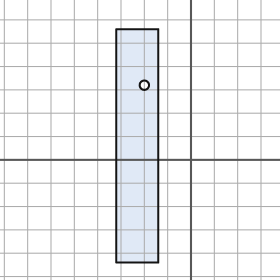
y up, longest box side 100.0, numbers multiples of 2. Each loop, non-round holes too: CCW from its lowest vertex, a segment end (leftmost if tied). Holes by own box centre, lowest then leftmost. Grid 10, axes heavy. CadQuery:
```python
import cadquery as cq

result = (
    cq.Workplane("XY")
    .moveTo(-32.0, -44.0)
    .lineTo(-14.0, -44.0)
    .lineTo(-14.0, 56.0)
    .lineTo(-32.0, 56.0)
    .close()
    .moveTo(-20.0, 32.0)
    .circle(2.0)
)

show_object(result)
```